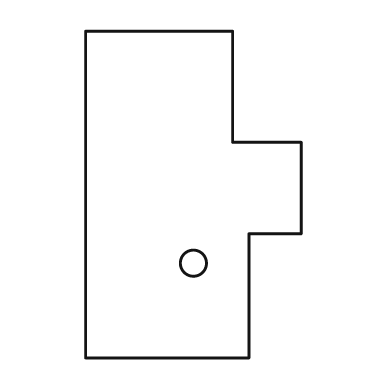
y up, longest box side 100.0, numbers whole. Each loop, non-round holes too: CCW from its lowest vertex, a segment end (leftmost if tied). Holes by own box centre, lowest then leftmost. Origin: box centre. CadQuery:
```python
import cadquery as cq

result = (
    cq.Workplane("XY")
    .moveTo(-33.0, -50.0)
    .lineTo(17.0, -50.0)
    .lineTo(17.0, -12.0)
    .lineTo(33.0, -12.0)
    .lineTo(33.0, 16.0)
    .lineTo(12.0, 16.0)
    .lineTo(12.0, 50.0)
    .lineTo(-33.0, 50.0)
    .close()
    .moveTo(0.0, -21.0)
    .circle(4.0)
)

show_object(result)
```